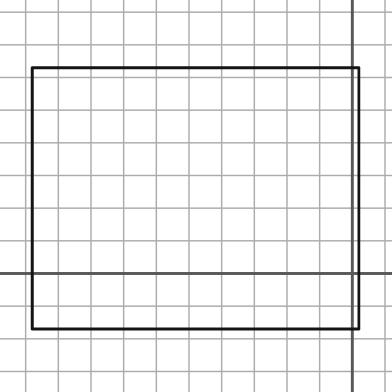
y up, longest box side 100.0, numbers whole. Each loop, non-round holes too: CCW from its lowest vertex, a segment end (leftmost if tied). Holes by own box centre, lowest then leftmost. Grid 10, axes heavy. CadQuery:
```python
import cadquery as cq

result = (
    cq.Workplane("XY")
    .moveTo(-98.0, -17.0)
    .lineTo(2.0, -17.0)
    .lineTo(2.0, 63.0)
    .lineTo(-98.0, 63.0)
    .close()
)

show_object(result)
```